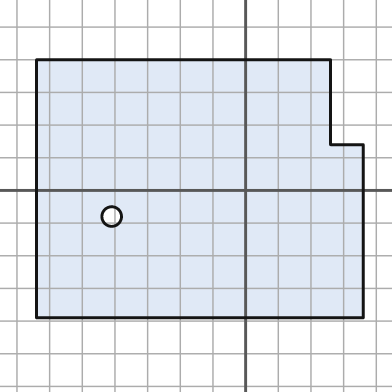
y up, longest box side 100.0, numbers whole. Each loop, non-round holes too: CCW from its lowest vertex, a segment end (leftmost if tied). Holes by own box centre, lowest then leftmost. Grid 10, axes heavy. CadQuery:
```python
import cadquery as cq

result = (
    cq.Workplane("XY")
    .moveTo(-64.0, -39.0)
    .lineTo(36.0, -39.0)
    .lineTo(36.0, 14.0)
    .lineTo(26.0, 14.0)
    .lineTo(26.0, 40.0)
    .lineTo(-64.0, 40.0)
    .close()
    .moveTo(-41.0, -8.0)
    .circle(3.0)
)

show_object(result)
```